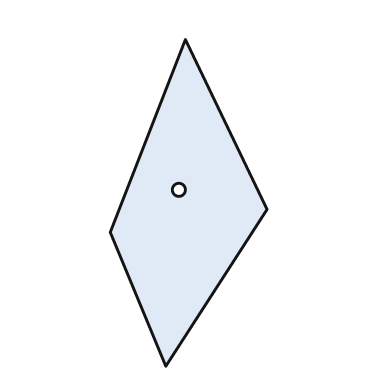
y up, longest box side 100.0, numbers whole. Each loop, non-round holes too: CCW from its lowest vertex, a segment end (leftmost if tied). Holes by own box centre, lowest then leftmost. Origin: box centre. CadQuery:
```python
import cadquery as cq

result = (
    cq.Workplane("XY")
    .moveTo(-7.0, -50.0)
    .lineTo(24.0, -2.0)
    .lineTo(-1.0, 50.0)
    .lineTo(-24.0, -9.0)
    .close()
    .moveTo(-3.0, 4.0)
    .circle(2.0)
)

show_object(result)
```